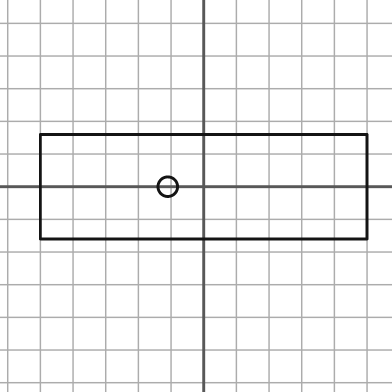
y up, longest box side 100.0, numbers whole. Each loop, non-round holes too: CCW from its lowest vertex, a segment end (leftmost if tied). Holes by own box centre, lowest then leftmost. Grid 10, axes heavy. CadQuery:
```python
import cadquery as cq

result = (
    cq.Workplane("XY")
    .moveTo(-50.0, -16.0)
    .lineTo(50.0, -16.0)
    .lineTo(50.0, 16.0)
    .lineTo(-50.0, 16.0)
    .close()
    .moveTo(-11.0, 0.0)
    .circle(3.0)
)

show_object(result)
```